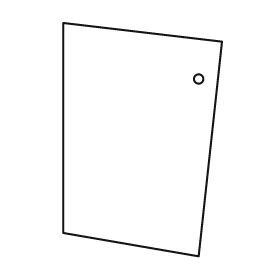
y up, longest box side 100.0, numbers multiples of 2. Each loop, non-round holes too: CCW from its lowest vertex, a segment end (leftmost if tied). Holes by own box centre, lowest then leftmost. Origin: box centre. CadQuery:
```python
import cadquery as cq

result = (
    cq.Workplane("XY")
    .moveTo(24.0, -50.0)
    .lineTo(34.0, 42.0)
    .lineTo(-34.0, 50.0)
    .lineTo(-34.0, -40.0)
    .close()
    .moveTo(24.0, 26.0)
    .circle(2.0)
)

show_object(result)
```